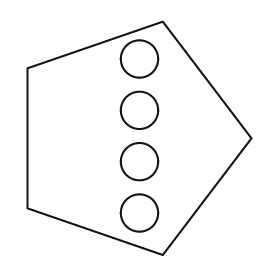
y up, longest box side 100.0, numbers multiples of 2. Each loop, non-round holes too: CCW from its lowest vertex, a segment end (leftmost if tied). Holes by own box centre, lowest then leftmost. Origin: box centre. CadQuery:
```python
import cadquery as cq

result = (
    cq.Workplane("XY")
    .moveTo(10.0, -50.0)
    .lineTo(48.0, 0.0)
    .lineTo(10.0, 50.0)
    .lineTo(-48.0, 30.0)
    .lineTo(-48.0, -30.0)
    .close()
    .moveTo(0.0, -32.0)
    .circle(8.0)
    .moveTo(0.0, -10.0)
    .circle(8.0)
    .moveTo(0.0, 12.0)
    .circle(8.0)
    .moveTo(0.0, 34.0)
    .circle(8.0)
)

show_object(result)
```